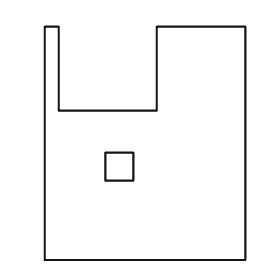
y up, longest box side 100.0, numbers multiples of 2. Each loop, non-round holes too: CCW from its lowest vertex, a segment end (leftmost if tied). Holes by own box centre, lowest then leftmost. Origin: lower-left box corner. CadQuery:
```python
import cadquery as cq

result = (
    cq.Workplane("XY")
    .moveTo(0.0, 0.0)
    .lineTo(86.0, 0.0)
    .lineTo(86.0, 100.0)
    .lineTo(48.0, 100.0)
    .lineTo(48.0, 64.0)
    .lineTo(6.0, 64.0)
    .lineTo(6.0, 100.0)
    .lineTo(0.0, 100.0)
    .close()
    .moveTo(26.0, 34.0)
    .lineTo(38.0, 34.0)
    .lineTo(38.0, 46.0)
    .lineTo(26.0, 46.0)
    .close()
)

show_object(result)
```